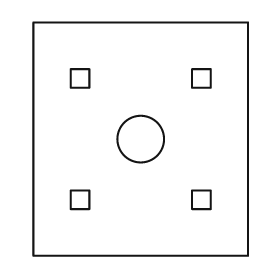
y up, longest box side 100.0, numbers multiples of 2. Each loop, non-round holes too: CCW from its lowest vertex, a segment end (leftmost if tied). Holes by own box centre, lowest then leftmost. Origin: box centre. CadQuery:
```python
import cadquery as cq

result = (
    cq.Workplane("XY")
    .moveTo(-46.0, -50.0)
    .lineTo(46.0, -50.0)
    .lineTo(46.0, 50.0)
    .lineTo(-46.0, 50.0)
    .close()
    .moveTo(-30.0, -30.0)
    .lineTo(-22.0, -30.0)
    .lineTo(-22.0, -22.0)
    .lineTo(-30.0, -22.0)
    .close()
    .moveTo(22.0, -30.0)
    .lineTo(30.0, -30.0)
    .lineTo(30.0, -22.0)
    .lineTo(22.0, -22.0)
    .close()
    .moveTo(0.0, 0.0)
    .circle(10.0)
    .moveTo(-30.0, 22.0)
    .lineTo(-22.0, 22.0)
    .lineTo(-22.0, 30.0)
    .lineTo(-30.0, 30.0)
    .close()
    .moveTo(22.0, 22.0)
    .lineTo(30.0, 22.0)
    .lineTo(30.0, 30.0)
    .lineTo(22.0, 30.0)
    .close()
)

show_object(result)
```